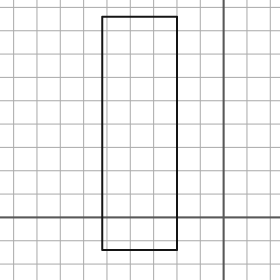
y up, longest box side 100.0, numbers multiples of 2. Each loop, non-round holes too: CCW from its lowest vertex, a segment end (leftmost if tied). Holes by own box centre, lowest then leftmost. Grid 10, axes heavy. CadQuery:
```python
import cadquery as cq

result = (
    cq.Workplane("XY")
    .moveTo(-52.0, -14.0)
    .lineTo(-20.0, -14.0)
    .lineTo(-20.0, 86.0)
    .lineTo(-52.0, 86.0)
    .close()
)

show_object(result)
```